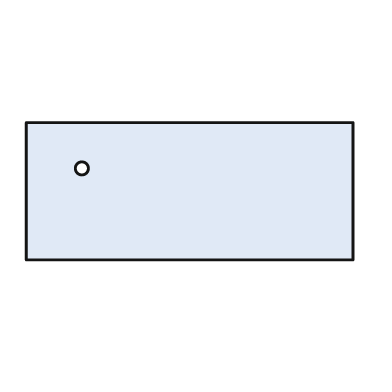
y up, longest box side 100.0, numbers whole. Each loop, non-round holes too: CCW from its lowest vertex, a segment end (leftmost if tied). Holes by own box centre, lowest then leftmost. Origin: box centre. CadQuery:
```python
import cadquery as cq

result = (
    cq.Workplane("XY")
    .moveTo(-50.0, -21.0)
    .lineTo(50.0, -21.0)
    .lineTo(50.0, 21.0)
    .lineTo(-50.0, 21.0)
    .close()
    .moveTo(-33.0, 7.0)
    .circle(2.0)
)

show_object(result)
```